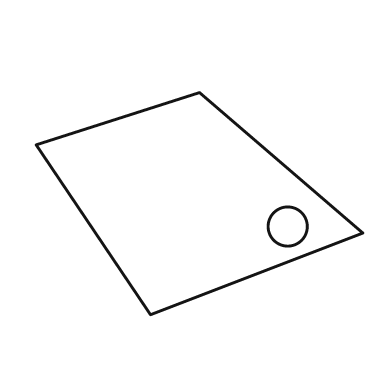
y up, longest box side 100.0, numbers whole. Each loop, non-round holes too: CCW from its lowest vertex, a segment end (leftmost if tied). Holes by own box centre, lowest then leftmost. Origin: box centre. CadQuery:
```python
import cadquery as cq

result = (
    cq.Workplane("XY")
    .moveTo(-15.0, -34.0)
    .lineTo(50.0, -9.0)
    .lineTo(0.0, 34.0)
    .lineTo(-50.0, 18.0)
    .close()
    .moveTo(27.0, -7.0)
    .circle(6.0)
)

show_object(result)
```